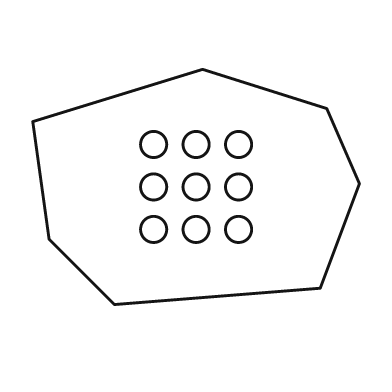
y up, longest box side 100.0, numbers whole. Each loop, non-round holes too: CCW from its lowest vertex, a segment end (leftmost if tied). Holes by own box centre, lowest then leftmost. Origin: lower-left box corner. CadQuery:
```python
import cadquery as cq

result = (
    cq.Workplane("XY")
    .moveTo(25.0, 0.0)
    .lineTo(88.0, 5.0)
    .lineTo(100.0, 37.0)
    .lineTo(90.0, 60.0)
    .lineTo(52.0, 72.0)
    .lineTo(0.0, 56.0)
    .lineTo(5.0, 20.0)
    .close()
    .moveTo(37.0, 23.0)
    .circle(4.0)
    .moveTo(50.0, 23.0)
    .circle(4.0)
    .moveTo(63.0, 23.0)
    .circle(4.0)
    .moveTo(37.0, 36.0)
    .circle(4.0)
    .moveTo(50.0, 36.0)
    .circle(4.0)
    .moveTo(63.0, 36.0)
    .circle(4.0)
    .moveTo(37.0, 49.0)
    .circle(4.0)
    .moveTo(50.0, 49.0)
    .circle(4.0)
    .moveTo(63.0, 49.0)
    .circle(4.0)
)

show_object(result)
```